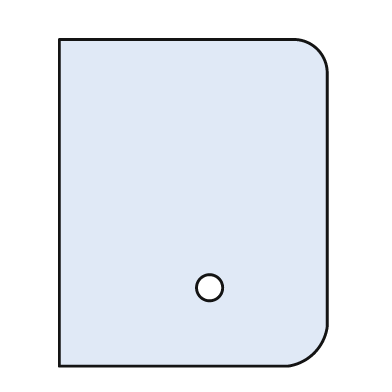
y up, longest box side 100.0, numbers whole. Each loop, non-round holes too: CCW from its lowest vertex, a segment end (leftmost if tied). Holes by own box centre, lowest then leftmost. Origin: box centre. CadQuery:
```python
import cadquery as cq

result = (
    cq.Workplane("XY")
    .moveTo(-41.0, -50.0)
    .lineTo(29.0, -50.0)
    .threePointArc((37.0, -46.0), (41.0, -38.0))
    .lineTo(41.0, 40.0)
    .threePointArc((38.0, 47.0), (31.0, 50.0))
    .lineTo(-41.0, 50.0)
    .close()
    .moveTo(5.0, -26.0)
    .circle(4.0)
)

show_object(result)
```